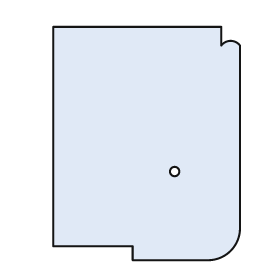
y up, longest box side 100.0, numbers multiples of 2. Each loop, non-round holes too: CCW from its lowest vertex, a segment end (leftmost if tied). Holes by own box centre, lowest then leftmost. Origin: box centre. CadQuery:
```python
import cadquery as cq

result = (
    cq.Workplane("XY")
    .moveTo(-6.0, -50.0)
    .lineTo(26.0, -50.0)
    .threePointArc((36.0, -46.0), (40.0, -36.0))
    .lineTo(40.0, 42.0)
    .threePointArc((36.0, 44.0), (32.0, 42.0))
    .lineTo(32.0, 50.0)
    .lineTo(-40.0, 50.0)
    .lineTo(-40.0, -44.0)
    .lineTo(-6.0, -44.0)
    .close()
    .moveTo(12.0, -12.0)
    .circle(2.0)
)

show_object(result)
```